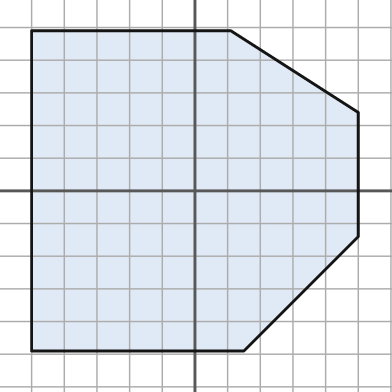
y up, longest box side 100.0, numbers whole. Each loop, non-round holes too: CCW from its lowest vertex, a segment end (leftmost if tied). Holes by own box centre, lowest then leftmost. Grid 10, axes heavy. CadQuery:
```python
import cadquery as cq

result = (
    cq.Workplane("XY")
    .moveTo(-50.0, -49.0)
    .lineTo(15.0, -49.0)
    .lineTo(50.0, -14.0)
    .lineTo(50.0, 24.0)
    .lineTo(11.0, 49.0)
    .lineTo(-50.0, 49.0)
    .close()
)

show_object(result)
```